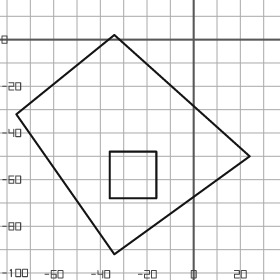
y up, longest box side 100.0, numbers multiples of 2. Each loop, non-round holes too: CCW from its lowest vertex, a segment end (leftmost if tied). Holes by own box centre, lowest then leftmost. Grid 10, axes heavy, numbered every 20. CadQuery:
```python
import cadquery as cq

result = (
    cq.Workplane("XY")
    .moveTo(-34.0, -92.0)
    .lineTo(24.0, -50.0)
    .lineTo(-34.0, 2.0)
    .lineTo(-76.0, -32.0)
    .close()
    .moveTo(-36.0, -68.0)
    .lineTo(-16.0, -68.0)
    .lineTo(-16.0, -48.0)
    .lineTo(-36.0, -48.0)
    .close()
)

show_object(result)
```